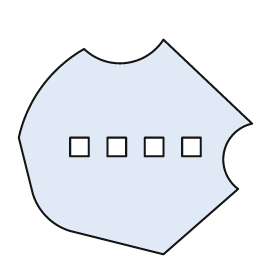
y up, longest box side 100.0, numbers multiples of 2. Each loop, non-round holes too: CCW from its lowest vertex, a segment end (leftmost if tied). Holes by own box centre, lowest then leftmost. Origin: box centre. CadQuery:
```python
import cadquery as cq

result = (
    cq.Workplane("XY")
    .moveTo(12.0, -46.0)
    .lineTo(44.0, -18.0)
    .threePointArc((38.0, -2.0), (50.0, 10.0))
    .lineTo(12.0, 46.0)
    .threePointArc((-4.0, 36.0), (-22.0, 42.0))
    .threePointArc((-40.0, 26.0), (-50.0, 4.0))
    .lineTo(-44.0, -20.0)
    .threePointArc((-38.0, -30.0), (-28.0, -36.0))
    .close()
    .moveTo(-28.0, -4.0)
    .lineTo(-20.0, -4.0)
    .lineTo(-20.0, 4.0)
    .lineTo(-28.0, 4.0)
    .close()
    .moveTo(-12.0, -4.0)
    .lineTo(-4.0, -4.0)
    .lineTo(-4.0, 4.0)
    .lineTo(-12.0, 4.0)
    .close()
    .moveTo(4.0, -4.0)
    .lineTo(12.0, -4.0)
    .lineTo(12.0, 4.0)
    .lineTo(4.0, 4.0)
    .close()
    .moveTo(20.0, -4.0)
    .lineTo(28.0, -4.0)
    .lineTo(28.0, 4.0)
    .lineTo(20.0, 4.0)
    .close()
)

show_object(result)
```